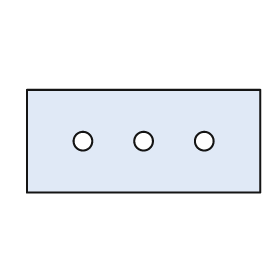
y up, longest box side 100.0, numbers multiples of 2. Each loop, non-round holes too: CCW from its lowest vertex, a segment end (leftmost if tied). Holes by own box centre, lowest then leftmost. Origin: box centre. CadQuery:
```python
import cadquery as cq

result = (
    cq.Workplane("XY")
    .moveTo(-50.0, -22.0)
    .lineTo(50.0, -22.0)
    .lineTo(50.0, 22.0)
    .lineTo(-50.0, 22.0)
    .close()
    .moveTo(-26.0, 0.0)
    .circle(4.0)
    .moveTo(0.0, 0.0)
    .circle(4.0)
    .moveTo(26.0, 0.0)
    .circle(4.0)
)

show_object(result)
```